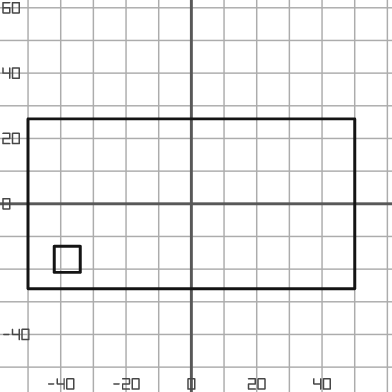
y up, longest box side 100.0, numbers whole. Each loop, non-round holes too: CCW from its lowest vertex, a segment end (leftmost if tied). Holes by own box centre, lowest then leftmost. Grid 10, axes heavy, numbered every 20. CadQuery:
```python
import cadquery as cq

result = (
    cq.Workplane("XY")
    .moveTo(-50.0, -26.0)
    .lineTo(50.0, -26.0)
    .lineTo(50.0, 26.0)
    .lineTo(-50.0, 26.0)
    .close()
    .moveTo(-42.0, -21.0)
    .lineTo(-34.0, -21.0)
    .lineTo(-34.0, -13.0)
    .lineTo(-42.0, -13.0)
    .close()
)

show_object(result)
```